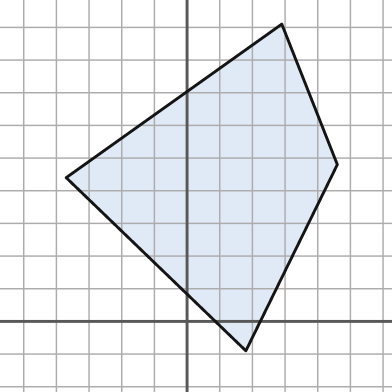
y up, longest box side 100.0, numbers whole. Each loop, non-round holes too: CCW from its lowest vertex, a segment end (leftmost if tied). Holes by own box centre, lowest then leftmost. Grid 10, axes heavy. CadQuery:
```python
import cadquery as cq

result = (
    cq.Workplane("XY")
    .moveTo(18.0, -9.0)
    .lineTo(46.0, 48.0)
    .lineTo(29.0, 91.0)
    .lineTo(-37.0, 44.0)
    .close()
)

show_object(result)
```